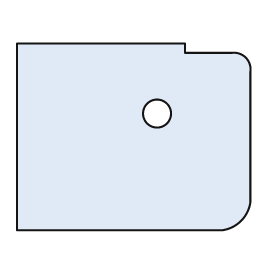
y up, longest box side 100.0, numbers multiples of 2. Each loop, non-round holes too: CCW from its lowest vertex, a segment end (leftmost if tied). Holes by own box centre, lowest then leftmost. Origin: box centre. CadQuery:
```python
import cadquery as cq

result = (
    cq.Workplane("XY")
    .moveTo(-50.0, -40.0)
    .lineTo(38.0, -40.0)
    .threePointArc((46.0, -36.0), (50.0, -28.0))
    .lineTo(50.0, 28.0)
    .threePointArc((48.0, 34.0), (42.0, 36.0))
    .lineTo(22.0, 36.0)
    .lineTo(22.0, 40.0)
    .lineTo(-50.0, 40.0)
    .close()
    .moveTo(10.0, 10.0)
    .circle(6.0)
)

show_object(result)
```